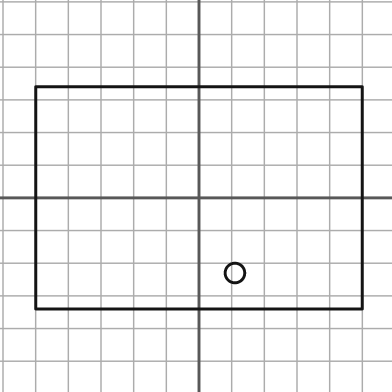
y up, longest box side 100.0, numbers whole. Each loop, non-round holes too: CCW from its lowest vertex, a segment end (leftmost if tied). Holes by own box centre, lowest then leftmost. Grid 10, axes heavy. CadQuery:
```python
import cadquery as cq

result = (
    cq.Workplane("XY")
    .moveTo(-50.0, -34.0)
    .lineTo(50.0, -34.0)
    .lineTo(50.0, 34.0)
    .lineTo(-50.0, 34.0)
    .close()
    .moveTo(11.0, -23.0)
    .circle(3.0)
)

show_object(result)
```